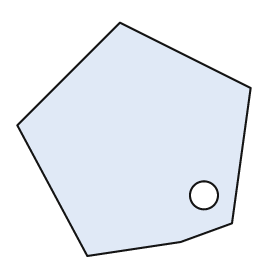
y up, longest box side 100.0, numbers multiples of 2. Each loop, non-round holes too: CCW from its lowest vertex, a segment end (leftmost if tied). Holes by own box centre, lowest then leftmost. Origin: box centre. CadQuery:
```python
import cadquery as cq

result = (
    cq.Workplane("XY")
    .moveTo(-20.0, -50.0)
    .lineTo(20.0, -44.0)
    .lineTo(42.0, -36.0)
    .lineTo(50.0, 22.0)
    .lineTo(-6.0, 50.0)
    .lineTo(-50.0, 6.0)
    .close()
    .moveTo(30.0, -24.0)
    .circle(6.0)
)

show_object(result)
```